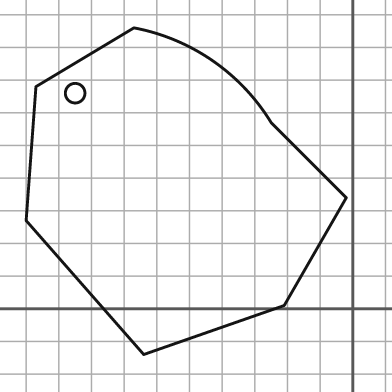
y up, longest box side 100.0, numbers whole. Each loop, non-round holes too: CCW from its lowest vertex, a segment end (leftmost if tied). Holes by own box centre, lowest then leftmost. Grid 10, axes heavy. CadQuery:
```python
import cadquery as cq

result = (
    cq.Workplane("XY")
    .moveTo(-64.0, -14.0)
    .lineTo(-21.0, 1.0)
    .lineTo(-2.0, 34.0)
    .lineTo(-25.0, 57.0)
    .threePointArc((-43.0, 76.0), (-67.0, 86.0))
    .lineTo(-97.0, 68.0)
    .lineTo(-100.0, 27.0)
    .close()
    .moveTo(-85.0, 66.0)
    .circle(3.0)
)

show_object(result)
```